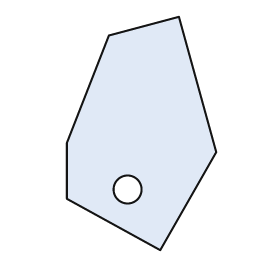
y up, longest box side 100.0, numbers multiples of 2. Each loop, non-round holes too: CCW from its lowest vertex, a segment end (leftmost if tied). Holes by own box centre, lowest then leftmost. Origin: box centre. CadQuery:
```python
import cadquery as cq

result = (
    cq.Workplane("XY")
    .moveTo(8.0, -50.0)
    .lineTo(32.0, -8.0)
    .lineTo(16.0, 50.0)
    .lineTo(-14.0, 42.0)
    .lineTo(-32.0, -4.0)
    .lineTo(-32.0, -28.0)
    .close()
    .moveTo(-6.0, -24.0)
    .circle(6.0)
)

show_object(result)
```